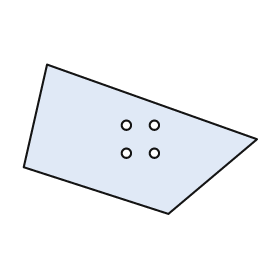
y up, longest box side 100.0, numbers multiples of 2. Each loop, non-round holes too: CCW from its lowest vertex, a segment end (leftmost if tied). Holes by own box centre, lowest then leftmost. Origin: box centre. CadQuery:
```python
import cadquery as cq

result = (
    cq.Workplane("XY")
    .moveTo(12.0, -32.0)
    .lineTo(50.0, 0.0)
    .lineTo(-40.0, 32.0)
    .lineTo(-50.0, -12.0)
    .close()
    .moveTo(-6.0, -6.0)
    .circle(2.0)
    .moveTo(6.0, -6.0)
    .circle(2.0)
    .moveTo(-6.0, 6.0)
    .circle(2.0)
    .moveTo(6.0, 6.0)
    .circle(2.0)
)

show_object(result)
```